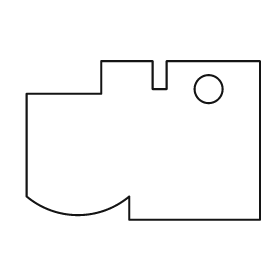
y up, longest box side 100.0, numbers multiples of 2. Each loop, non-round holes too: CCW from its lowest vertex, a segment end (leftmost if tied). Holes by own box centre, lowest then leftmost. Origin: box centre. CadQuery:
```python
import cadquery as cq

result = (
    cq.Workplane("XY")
    .moveTo(-6.0, -34.0)
    .lineTo(50.0, -34.0)
    .lineTo(50.0, 34.0)
    .lineTo(10.0, 34.0)
    .lineTo(10.0, 22.0)
    .lineTo(4.0, 22.0)
    .lineTo(4.0, 34.0)
    .lineTo(-18.0, 34.0)
    .lineTo(-18.0, 20.0)
    .lineTo(-50.0, 20.0)
    .lineTo(-50.0, -24.0)
    .threePointArc((-28.0, -32.0), (-6.0, -24.0))
    .close()
    .moveTo(28.0, 22.0)
    .circle(6.0)
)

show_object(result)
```